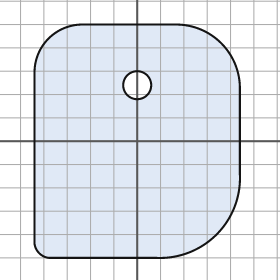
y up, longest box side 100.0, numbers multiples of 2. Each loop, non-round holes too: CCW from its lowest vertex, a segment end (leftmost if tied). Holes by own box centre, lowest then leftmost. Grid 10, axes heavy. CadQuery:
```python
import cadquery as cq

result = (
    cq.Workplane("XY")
    .moveTo(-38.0, -50.0)
    .lineTo(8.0, -50.0)
    .threePointArc((34.0, -40.0), (44.0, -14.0))
    .lineTo(44.0, 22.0)
    .threePointArc((36.0, 42.0), (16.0, 50.0))
    .lineTo(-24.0, 50.0)
    .threePointArc((-38.0, 44.0), (-44.0, 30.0))
    .lineTo(-44.0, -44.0)
    .threePointArc((-42.0, -48.0), (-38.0, -50.0))
    .close()
    .moveTo(0.0, 24.0)
    .circle(6.0)
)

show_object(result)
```